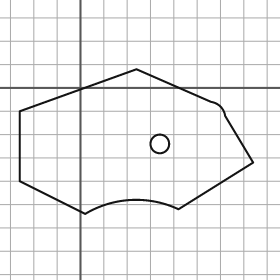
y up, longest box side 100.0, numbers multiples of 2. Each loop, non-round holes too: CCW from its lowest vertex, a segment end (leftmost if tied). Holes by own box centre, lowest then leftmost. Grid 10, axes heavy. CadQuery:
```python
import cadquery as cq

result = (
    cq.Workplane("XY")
    .moveTo(2.0, -54.0)
    .threePointArc((22.0, -48.0), (42.0, -52.0))
    .lineTo(74.0, -32.0)
    .lineTo(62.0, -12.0)
    .threePointArc((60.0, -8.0), (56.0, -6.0))
    .lineTo(24.0, 8.0)
    .lineTo(-26.0, -10.0)
    .lineTo(-26.0, -40.0)
    .close()
    .moveTo(34.0, -24.0)
    .circle(4.0)
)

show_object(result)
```